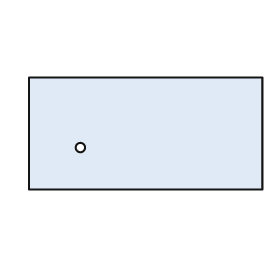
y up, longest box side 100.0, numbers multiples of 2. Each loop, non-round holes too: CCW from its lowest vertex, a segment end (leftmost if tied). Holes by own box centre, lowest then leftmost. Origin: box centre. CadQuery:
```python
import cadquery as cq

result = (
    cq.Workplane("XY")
    .moveTo(-50.0, -24.0)
    .lineTo(50.0, -24.0)
    .lineTo(50.0, 24.0)
    .lineTo(-50.0, 24.0)
    .close()
    .moveTo(-28.0, -6.0)
    .circle(2.0)
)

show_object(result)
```